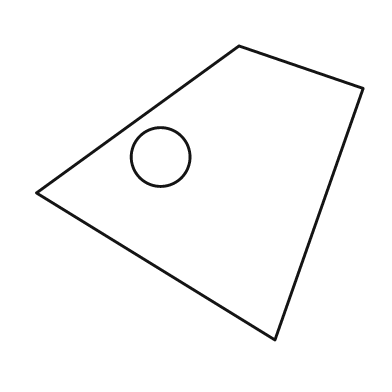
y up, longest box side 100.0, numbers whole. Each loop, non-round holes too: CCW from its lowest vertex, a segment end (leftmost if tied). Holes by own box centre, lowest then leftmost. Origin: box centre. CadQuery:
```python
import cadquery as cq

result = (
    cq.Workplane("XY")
    .moveTo(23.0, -45.0)
    .lineTo(50.0, 32.0)
    .lineTo(12.0, 45.0)
    .lineTo(-50.0, 0.0)
    .close()
    .moveTo(-12.0, 11.0)
    .circle(9.0)
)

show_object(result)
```